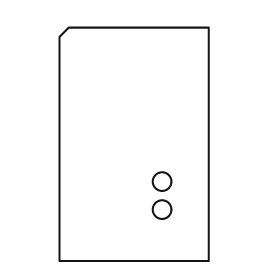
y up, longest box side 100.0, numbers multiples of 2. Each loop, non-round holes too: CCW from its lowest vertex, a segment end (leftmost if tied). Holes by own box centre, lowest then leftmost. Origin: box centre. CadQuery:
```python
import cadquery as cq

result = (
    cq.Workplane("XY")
    .moveTo(-32.0, -50.0)
    .lineTo(32.0, -50.0)
    .lineTo(32.0, 50.0)
    .lineTo(-28.0, 50.0)
    .lineTo(-32.0, 46.0)
    .close()
    .moveTo(12.0, -28.0)
    .circle(4.0)
    .moveTo(12.0, -16.0)
    .circle(4.0)
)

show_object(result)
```